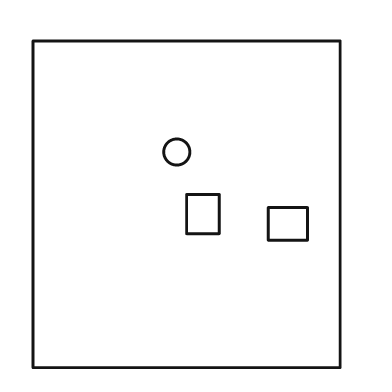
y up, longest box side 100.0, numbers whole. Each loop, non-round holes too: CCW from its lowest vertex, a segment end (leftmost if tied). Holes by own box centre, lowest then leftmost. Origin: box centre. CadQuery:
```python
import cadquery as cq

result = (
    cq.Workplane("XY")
    .moveTo(-47.0, -50.0)
    .lineTo(47.0, -50.0)
    .lineTo(47.0, 50.0)
    .lineTo(-47.0, 50.0)
    .close()
    .moveTo(25.0, -11.0)
    .lineTo(37.0, -11.0)
    .lineTo(37.0, -1.0)
    .lineTo(25.0, -1.0)
    .close()
    .moveTo(0.0, -9.0)
    .lineTo(10.0, -9.0)
    .lineTo(10.0, 3.0)
    .lineTo(0.0, 3.0)
    .close()
    .moveTo(-3.0, 16.0)
    .circle(4.0)
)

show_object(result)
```